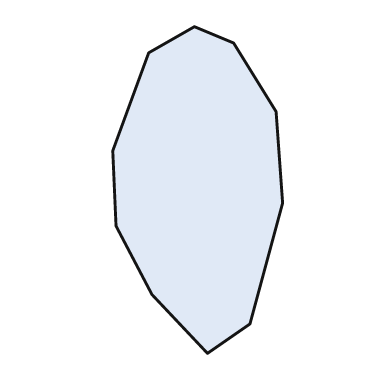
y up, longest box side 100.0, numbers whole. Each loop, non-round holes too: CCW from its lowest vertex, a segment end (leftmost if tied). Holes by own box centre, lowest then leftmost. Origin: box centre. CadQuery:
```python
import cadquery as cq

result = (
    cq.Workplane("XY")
    .moveTo(3.0, -50.0)
    .lineTo(16.0, -41.0)
    .lineTo(26.0, -4.0)
    .lineTo(24.0, 24.0)
    .lineTo(11.0, 45.0)
    .lineTo(-1.0, 50.0)
    .lineTo(-15.0, 42.0)
    .lineTo(-26.0, 12.0)
    .lineTo(-25.0, -11.0)
    .lineTo(-14.0, -32.0)
    .close()
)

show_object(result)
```